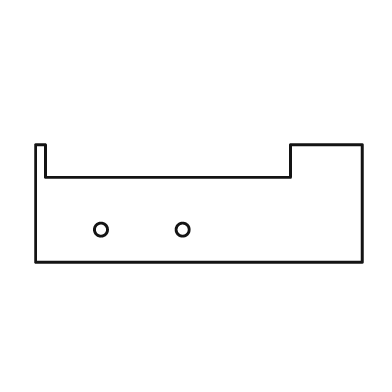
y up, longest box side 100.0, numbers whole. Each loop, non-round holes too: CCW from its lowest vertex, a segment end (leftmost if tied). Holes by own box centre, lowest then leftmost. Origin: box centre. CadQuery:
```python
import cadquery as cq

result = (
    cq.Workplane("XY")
    .moveTo(-50.0, -18.0)
    .lineTo(50.0, -18.0)
    .lineTo(50.0, 18.0)
    .lineTo(28.0, 18.0)
    .lineTo(28.0, 8.0)
    .lineTo(-47.0, 8.0)
    .lineTo(-47.0, 18.0)
    .lineTo(-50.0, 18.0)
    .close()
    .moveTo(-30.0, -8.0)
    .circle(2.0)
    .moveTo(-5.0, -8.0)
    .circle(2.0)
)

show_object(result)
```